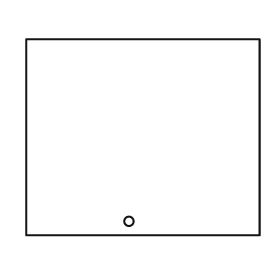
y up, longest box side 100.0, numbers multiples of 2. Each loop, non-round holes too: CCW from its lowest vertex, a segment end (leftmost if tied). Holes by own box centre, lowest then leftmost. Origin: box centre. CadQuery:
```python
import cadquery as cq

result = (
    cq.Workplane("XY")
    .moveTo(-50.0, -42.0)
    .lineTo(50.0, -42.0)
    .lineTo(50.0, 42.0)
    .lineTo(-50.0, 42.0)
    .close()
    .moveTo(-6.0, -36.0)
    .circle(2.0)
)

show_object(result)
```